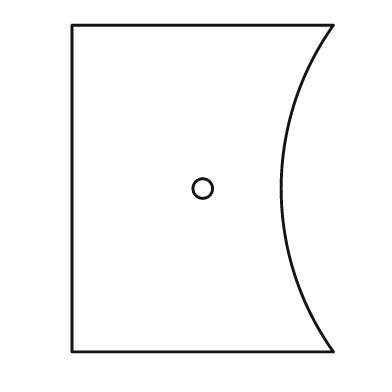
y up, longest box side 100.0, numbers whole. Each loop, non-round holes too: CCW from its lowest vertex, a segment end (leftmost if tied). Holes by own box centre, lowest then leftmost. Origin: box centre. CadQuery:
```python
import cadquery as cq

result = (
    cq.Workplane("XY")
    .moveTo(-40.0, -50.0)
    .lineTo(40.0, -50.0)
    .threePointArc((24.0, 0.0), (40.0, 50.0))
    .lineTo(-40.0, 50.0)
    .close()
    .moveTo(0.0, 0.0)
    .circle(3.0)
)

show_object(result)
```